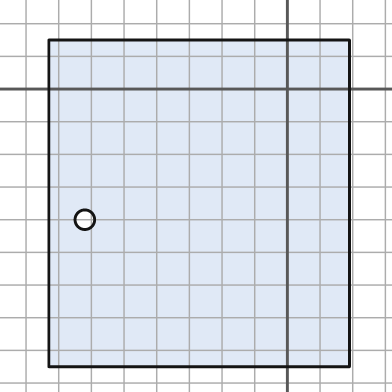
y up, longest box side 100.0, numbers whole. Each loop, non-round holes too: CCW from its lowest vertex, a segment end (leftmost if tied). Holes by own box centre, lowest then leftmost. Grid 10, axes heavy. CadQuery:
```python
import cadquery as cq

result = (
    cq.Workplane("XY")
    .moveTo(-73.0, -85.0)
    .lineTo(19.0, -85.0)
    .lineTo(19.0, 15.0)
    .lineTo(-73.0, 15.0)
    .close()
    .moveTo(-62.0, -40.0)
    .circle(3.0)
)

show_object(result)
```